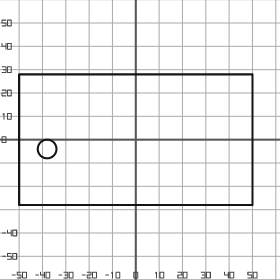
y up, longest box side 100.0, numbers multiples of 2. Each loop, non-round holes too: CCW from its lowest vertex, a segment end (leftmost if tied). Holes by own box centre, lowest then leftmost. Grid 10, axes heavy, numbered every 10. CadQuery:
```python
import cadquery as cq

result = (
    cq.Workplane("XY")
    .moveTo(-50.0, -28.0)
    .lineTo(50.0, -28.0)
    .lineTo(50.0, 28.0)
    .lineTo(-50.0, 28.0)
    .close()
    .moveTo(-38.0, -4.0)
    .circle(4.0)
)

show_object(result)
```